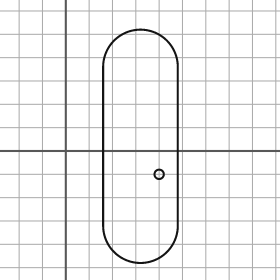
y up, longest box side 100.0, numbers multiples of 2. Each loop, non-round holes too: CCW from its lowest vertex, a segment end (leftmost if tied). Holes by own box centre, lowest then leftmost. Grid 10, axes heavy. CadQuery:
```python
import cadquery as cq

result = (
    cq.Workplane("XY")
    .moveTo(16.0, -32.0)
    .threePointArc((32.0, -48.0), (48.0, -32.0))
    .lineTo(48.0, 36.0)
    .threePointArc((32.0, 52.0), (16.0, 36.0))
    .close()
    .moveTo(40.0, -10.0)
    .circle(2.0)
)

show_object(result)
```